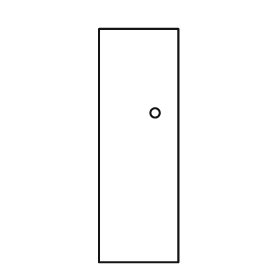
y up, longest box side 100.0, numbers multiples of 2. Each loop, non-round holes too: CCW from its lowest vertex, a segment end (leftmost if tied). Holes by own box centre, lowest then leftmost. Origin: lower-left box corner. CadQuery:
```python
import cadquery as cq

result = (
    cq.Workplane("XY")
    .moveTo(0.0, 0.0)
    .lineTo(34.0, 0.0)
    .lineTo(34.0, 100.0)
    .lineTo(0.0, 100.0)
    .close()
    .moveTo(24.0, 64.0)
    .circle(2.0)
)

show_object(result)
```